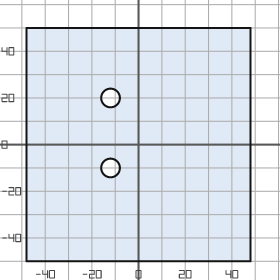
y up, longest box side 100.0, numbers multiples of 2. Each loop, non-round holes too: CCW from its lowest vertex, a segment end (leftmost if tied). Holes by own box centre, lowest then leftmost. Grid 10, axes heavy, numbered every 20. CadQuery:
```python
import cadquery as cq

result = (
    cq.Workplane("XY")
    .moveTo(-48.0, -50.0)
    .lineTo(48.0, -50.0)
    .lineTo(48.0, 50.0)
    .lineTo(-48.0, 50.0)
    .close()
    .moveTo(-12.0, -10.0)
    .circle(4.0)
    .moveTo(-12.0, 20.0)
    .circle(4.0)
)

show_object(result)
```